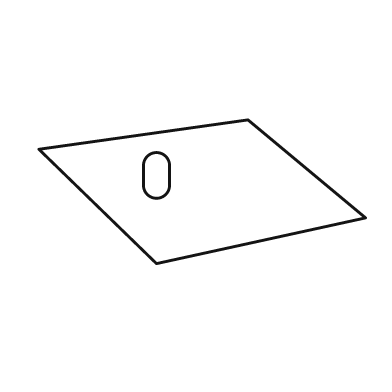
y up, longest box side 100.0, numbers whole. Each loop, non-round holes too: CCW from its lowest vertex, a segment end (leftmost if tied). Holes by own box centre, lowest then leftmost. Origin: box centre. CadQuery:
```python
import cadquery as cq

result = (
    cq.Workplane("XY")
    .moveTo(-14.0, -22.0)
    .lineTo(50.0, -8.0)
    .lineTo(14.0, 22.0)
    .lineTo(-50.0, 13.0)
    .close()
    .moveTo(-18.0, 2.0)
    .threePointArc((-14.0, -2.0), (-10.0, 2.0))
    .lineTo(-10.0, 8.0)
    .threePointArc((-14.0, 12.0), (-18.0, 8.0))
    .close()
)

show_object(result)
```